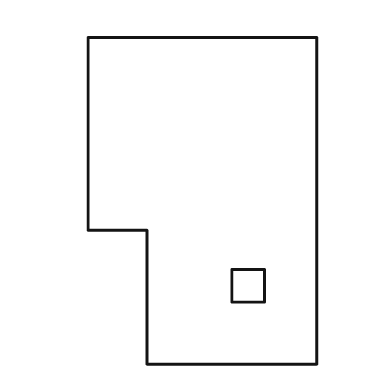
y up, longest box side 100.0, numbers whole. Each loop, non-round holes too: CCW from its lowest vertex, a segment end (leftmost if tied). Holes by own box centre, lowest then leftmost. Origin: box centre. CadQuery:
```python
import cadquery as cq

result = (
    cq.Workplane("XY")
    .moveTo(-17.0, -50.0)
    .lineTo(35.0, -50.0)
    .lineTo(35.0, 50.0)
    .lineTo(-35.0, 50.0)
    .lineTo(-35.0, -9.0)
    .lineTo(-17.0, -9.0)
    .close()
    .moveTo(9.0, -31.0)
    .lineTo(19.0, -31.0)
    .lineTo(19.0, -21.0)
    .lineTo(9.0, -21.0)
    .close()
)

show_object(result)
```